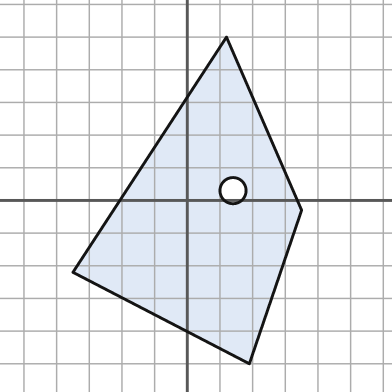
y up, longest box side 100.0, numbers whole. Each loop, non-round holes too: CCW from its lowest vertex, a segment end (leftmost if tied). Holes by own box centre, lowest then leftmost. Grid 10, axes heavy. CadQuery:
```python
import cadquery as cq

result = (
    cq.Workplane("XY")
    .moveTo(19.0, -50.0)
    .lineTo(35.0, -3.0)
    .lineTo(12.0, 50.0)
    .lineTo(-35.0, -22.0)
    .close()
    .moveTo(14.0, 3.0)
    .circle(4.0)
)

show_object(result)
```